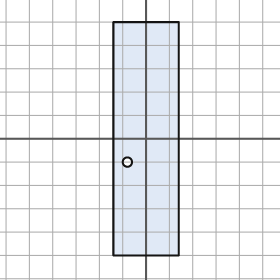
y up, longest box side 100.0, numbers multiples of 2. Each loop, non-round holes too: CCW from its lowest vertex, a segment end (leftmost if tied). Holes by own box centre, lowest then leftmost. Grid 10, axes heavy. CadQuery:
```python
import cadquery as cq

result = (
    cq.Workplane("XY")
    .moveTo(-14.0, -50.0)
    .lineTo(14.0, -50.0)
    .lineTo(14.0, 50.0)
    .lineTo(-14.0, 50.0)
    .close()
    .moveTo(-8.0, -10.0)
    .circle(2.0)
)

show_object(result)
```